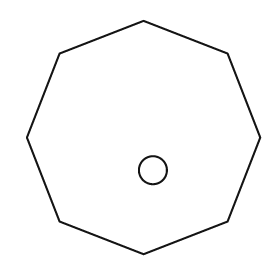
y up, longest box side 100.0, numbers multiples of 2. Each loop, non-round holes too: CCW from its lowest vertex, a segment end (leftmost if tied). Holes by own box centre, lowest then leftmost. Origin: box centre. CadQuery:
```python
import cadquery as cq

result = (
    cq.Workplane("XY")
    .moveTo(0.0, -50.0)
    .lineTo(36.0, -36.0)
    .lineTo(50.0, 0.0)
    .lineTo(36.0, 36.0)
    .lineTo(0.0, 50.0)
    .lineTo(-36.0, 36.0)
    .lineTo(-50.0, 0.0)
    .lineTo(-36.0, -36.0)
    .close()
    .moveTo(4.0, -14.0)
    .circle(6.0)
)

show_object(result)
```